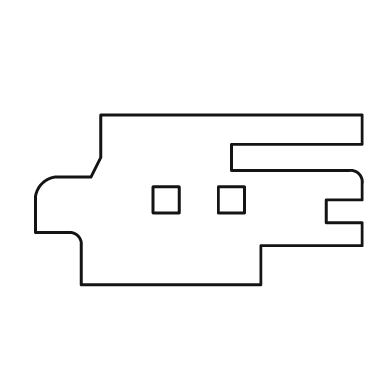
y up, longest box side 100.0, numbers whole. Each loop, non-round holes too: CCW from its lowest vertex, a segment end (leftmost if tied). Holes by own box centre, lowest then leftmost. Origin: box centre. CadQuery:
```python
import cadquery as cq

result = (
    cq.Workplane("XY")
    .moveTo(-36.0, -26.0)
    .lineTo(19.0, -26.0)
    .lineTo(19.0, -14.0)
    .lineTo(50.0, -14.0)
    .lineTo(50.0, -7.0)
    .lineTo(39.0, -7.0)
    .lineTo(39.0, 0.0)
    .lineTo(50.0, 0.0)
    .lineTo(50.0, 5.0)
    .threePointArc((49.0, 8.0), (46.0, 9.0))
    .lineTo(10.0, 9.0)
    .lineTo(10.0, 17.0)
    .lineTo(50.0, 17.0)
    .lineTo(50.0, 26.0)
    .lineTo(-30.0, 26.0)
    .lineTo(-30.0, 13.0)
    .lineTo(-33.0, 7.0)
    .lineTo(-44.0, 7.0)
    .threePointArc((-48.0, 5.0), (-50.0, 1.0))
    .lineTo(-50.0, -10.0)
    .lineTo(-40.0, -10.0)
    .threePointArc((-37.0, -11.0), (-36.0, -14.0))
    .close()
    .moveTo(-14.0, -4.0)
    .lineTo(-6.0, -4.0)
    .lineTo(-6.0, 4.0)
    .lineTo(-14.0, 4.0)
    .close()
    .moveTo(6.0, -4.0)
    .lineTo(14.0, -4.0)
    .lineTo(14.0, 4.0)
    .lineTo(6.0, 4.0)
    .close()
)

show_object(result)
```